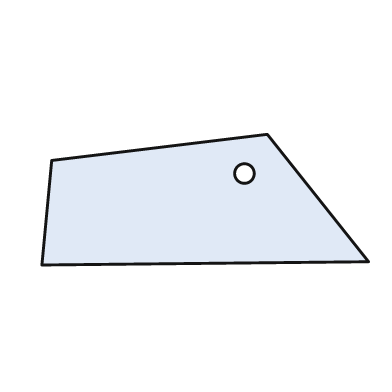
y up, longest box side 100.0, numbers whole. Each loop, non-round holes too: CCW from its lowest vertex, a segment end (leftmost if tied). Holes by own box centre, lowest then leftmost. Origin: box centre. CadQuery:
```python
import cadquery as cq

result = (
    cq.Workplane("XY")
    .moveTo(-50.0, -20.0)
    .lineTo(50.0, -19.0)
    .lineTo(19.0, 20.0)
    .lineTo(-47.0, 12.0)
    .close()
    .moveTo(12.0, 8.0)
    .circle(3.0)
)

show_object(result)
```